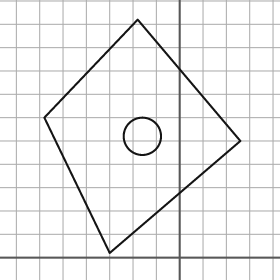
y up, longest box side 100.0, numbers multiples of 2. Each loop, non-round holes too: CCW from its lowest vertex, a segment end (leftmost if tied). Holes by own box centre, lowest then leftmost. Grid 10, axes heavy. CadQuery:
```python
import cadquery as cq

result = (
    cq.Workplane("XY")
    .moveTo(-30.0, 2.0)
    .lineTo(26.0, 50.0)
    .lineTo(-18.0, 102.0)
    .lineTo(-58.0, 60.0)
    .close()
    .moveTo(-16.0, 52.0)
    .circle(8.0)
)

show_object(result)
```